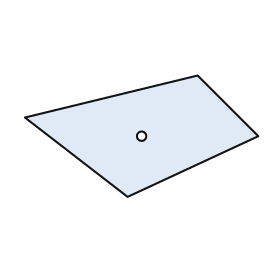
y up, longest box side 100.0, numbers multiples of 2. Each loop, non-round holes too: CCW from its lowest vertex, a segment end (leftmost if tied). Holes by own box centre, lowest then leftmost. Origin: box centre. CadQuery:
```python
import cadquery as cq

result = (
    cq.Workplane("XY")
    .moveTo(-6.0, -26.0)
    .lineTo(50.0, 0.0)
    .lineTo(24.0, 26.0)
    .lineTo(-50.0, 8.0)
    .close()
    .moveTo(0.0, 0.0)
    .circle(2.0)
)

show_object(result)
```